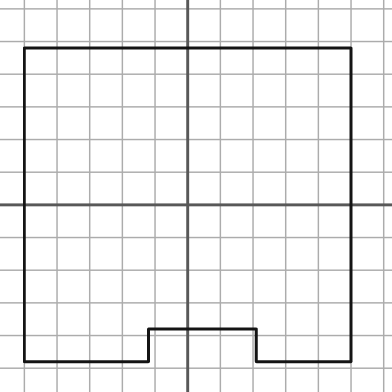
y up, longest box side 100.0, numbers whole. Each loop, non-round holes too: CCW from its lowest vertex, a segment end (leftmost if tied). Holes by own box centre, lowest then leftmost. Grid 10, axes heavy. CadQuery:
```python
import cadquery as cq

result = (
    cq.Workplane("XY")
    .moveTo(-50.0, -48.0)
    .lineTo(-12.0, -48.0)
    .lineTo(-12.0, -38.0)
    .lineTo(21.0, -38.0)
    .lineTo(21.0, -48.0)
    .lineTo(50.0, -48.0)
    .lineTo(50.0, 48.0)
    .lineTo(-50.0, 48.0)
    .close()
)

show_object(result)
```